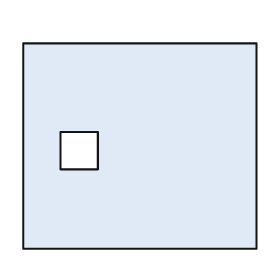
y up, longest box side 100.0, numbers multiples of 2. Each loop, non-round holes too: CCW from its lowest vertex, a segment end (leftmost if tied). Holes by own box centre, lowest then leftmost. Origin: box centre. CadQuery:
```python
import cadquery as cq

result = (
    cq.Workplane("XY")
    .moveTo(-50.0, -44.0)
    .lineTo(50.0, -44.0)
    .lineTo(50.0, 44.0)
    .lineTo(-50.0, 44.0)
    .close()
    .moveTo(-34.0, -10.0)
    .lineTo(-18.0, -10.0)
    .lineTo(-18.0, 6.0)
    .lineTo(-34.0, 6.0)
    .close()
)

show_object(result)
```